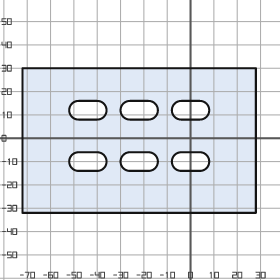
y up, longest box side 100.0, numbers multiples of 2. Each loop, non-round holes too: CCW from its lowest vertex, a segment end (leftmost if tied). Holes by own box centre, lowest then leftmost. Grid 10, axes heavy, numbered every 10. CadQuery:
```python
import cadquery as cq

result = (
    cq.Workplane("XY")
    .moveTo(-72.0, -32.0)
    .lineTo(28.0, -32.0)
    .lineTo(28.0, 30.0)
    .lineTo(-72.0, 30.0)
    .close()
    .moveTo(-48.0, -14.0)
    .lineTo(-40.0, -14.0)
    .threePointArc((-36.0, -10.0), (-40.0, -6.0))
    .lineTo(-48.0, -6.0)
    .threePointArc((-52.0, -10.0), (-48.0, -14.0))
    .close()
    .moveTo(-26.0, -14.0)
    .lineTo(-18.0, -14.0)
    .threePointArc((-14.0, -10.0), (-18.0, -6.0))
    .lineTo(-26.0, -6.0)
    .threePointArc((-30.0, -10.0), (-26.0, -14.0))
    .close()
    .moveTo(-4.0, -14.0)
    .lineTo(4.0, -14.0)
    .threePointArc((8.0, -10.0), (4.0, -6.0))
    .lineTo(-4.0, -6.0)
    .threePointArc((-8.0, -10.0), (-4.0, -14.0))
    .close()
    .moveTo(-48.0, 8.0)
    .lineTo(-40.0, 8.0)
    .threePointArc((-36.0, 12.0), (-40.0, 16.0))
    .lineTo(-48.0, 16.0)
    .threePointArc((-52.0, 12.0), (-48.0, 8.0))
    .close()
    .moveTo(-26.0, 8.0)
    .lineTo(-18.0, 8.0)
    .threePointArc((-14.0, 12.0), (-18.0, 16.0))
    .lineTo(-26.0, 16.0)
    .threePointArc((-30.0, 12.0), (-26.0, 8.0))
    .close()
    .moveTo(-4.0, 8.0)
    .lineTo(4.0, 8.0)
    .threePointArc((8.0, 12.0), (4.0, 16.0))
    .lineTo(-4.0, 16.0)
    .threePointArc((-8.0, 12.0), (-4.0, 8.0))
    .close()
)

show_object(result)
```